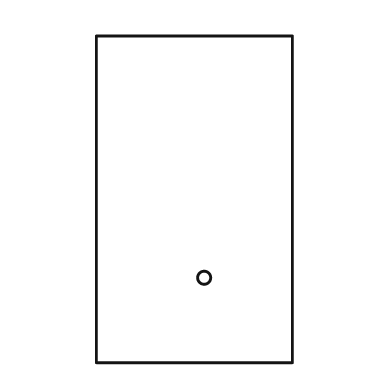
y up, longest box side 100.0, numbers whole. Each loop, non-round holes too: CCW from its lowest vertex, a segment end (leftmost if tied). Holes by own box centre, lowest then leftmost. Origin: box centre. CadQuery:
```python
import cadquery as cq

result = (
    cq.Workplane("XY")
    .moveTo(-30.0, -50.0)
    .lineTo(30.0, -50.0)
    .lineTo(30.0, 50.0)
    .lineTo(-30.0, 50.0)
    .close()
    .moveTo(3.0, -24.0)
    .circle(2.0)
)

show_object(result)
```